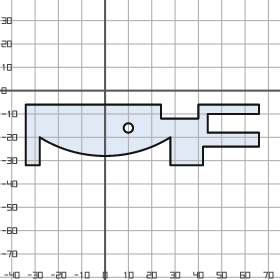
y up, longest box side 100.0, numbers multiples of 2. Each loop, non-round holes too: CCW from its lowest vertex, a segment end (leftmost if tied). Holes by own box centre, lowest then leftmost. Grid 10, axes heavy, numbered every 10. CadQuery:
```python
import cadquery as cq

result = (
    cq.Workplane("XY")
    .moveTo(-34.0, -32.0)
    .lineTo(-28.0, -32.0)
    .lineTo(-28.0, -20.0)
    .threePointArc((0.0, -28.0), (28.0, -20.0))
    .lineTo(28.0, -32.0)
    .lineTo(42.0, -32.0)
    .lineTo(42.0, -24.0)
    .lineTo(66.0, -24.0)
    .lineTo(66.0, -18.0)
    .lineTo(44.0, -18.0)
    .lineTo(44.0, -10.0)
    .lineTo(66.0, -10.0)
    .lineTo(66.0, -6.0)
    .lineTo(40.0, -6.0)
    .lineTo(40.0, -12.0)
    .lineTo(24.0, -12.0)
    .lineTo(24.0, -6.0)
    .lineTo(-34.0, -6.0)
    .close()
    .moveTo(10.0, -16.0)
    .circle(2.0)
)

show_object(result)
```